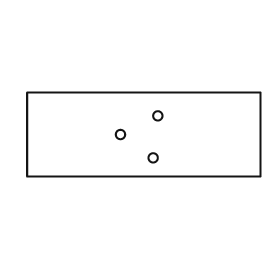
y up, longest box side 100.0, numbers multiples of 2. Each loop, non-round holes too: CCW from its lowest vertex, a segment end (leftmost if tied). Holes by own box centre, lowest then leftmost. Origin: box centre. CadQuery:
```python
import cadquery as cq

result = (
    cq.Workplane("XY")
    .moveTo(-50.0, -18.0)
    .lineTo(50.0, -18.0)
    .lineTo(50.0, 18.0)
    .lineTo(-50.0, 18.0)
    .close()
    .moveTo(4.0, -10.0)
    .circle(2.0)
    .moveTo(-10.0, 0.0)
    .circle(2.0)
    .moveTo(6.0, 8.0)
    .circle(2.0)
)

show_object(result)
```